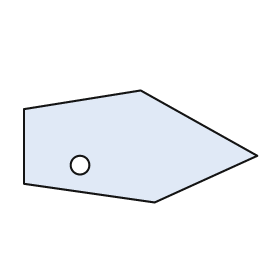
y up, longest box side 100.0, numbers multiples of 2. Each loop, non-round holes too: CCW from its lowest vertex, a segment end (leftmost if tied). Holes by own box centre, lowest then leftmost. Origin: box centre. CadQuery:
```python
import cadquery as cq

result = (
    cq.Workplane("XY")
    .moveTo(6.0, -24.0)
    .lineTo(50.0, -4.0)
    .lineTo(0.0, 24.0)
    .lineTo(-50.0, 16.0)
    .lineTo(-50.0, -16.0)
    .close()
    .moveTo(-26.0, -8.0)
    .circle(4.0)
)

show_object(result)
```